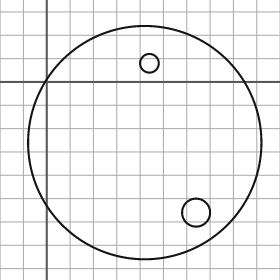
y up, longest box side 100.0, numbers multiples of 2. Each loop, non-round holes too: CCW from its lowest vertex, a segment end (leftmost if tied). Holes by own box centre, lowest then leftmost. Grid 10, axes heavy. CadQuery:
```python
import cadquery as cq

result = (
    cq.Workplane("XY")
    .moveTo(42.0, -26.0)
    .circle(50.0)
    .moveTo(64.0, -56.0)
    .circle(6.0)
    .moveTo(44.0, 8.0)
    .circle(4.0)
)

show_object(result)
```